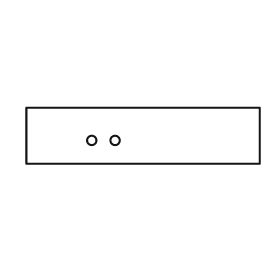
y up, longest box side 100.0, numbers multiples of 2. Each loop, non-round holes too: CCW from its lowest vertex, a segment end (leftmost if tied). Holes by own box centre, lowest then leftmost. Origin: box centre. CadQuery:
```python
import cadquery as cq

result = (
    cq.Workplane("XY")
    .moveTo(-50.0, -12.0)
    .lineTo(50.0, -12.0)
    .lineTo(50.0, 12.0)
    .lineTo(-50.0, 12.0)
    .close()
    .moveTo(-22.0, -2.0)
    .circle(2.0)
    .moveTo(-12.0, -2.0)
    .circle(2.0)
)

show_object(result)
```